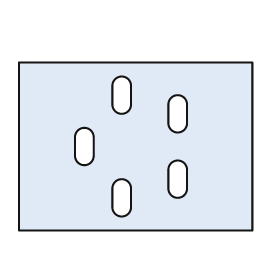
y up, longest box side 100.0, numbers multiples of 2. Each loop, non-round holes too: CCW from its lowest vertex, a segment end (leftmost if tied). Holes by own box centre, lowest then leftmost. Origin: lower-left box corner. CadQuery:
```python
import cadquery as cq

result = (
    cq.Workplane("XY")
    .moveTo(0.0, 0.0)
    .lineTo(100.0, 0.0)
    .lineTo(100.0, 72.0)
    .lineTo(0.0, 72.0)
    .close()
    .moveTo(40.0, 10.0)
    .threePointArc((44.0, 6.0), (48.0, 10.0))
    .lineTo(48.0, 18.0)
    .threePointArc((44.0, 22.0), (40.0, 18.0))
    .close()
    .moveTo(64.0, 18.0)
    .threePointArc((68.0, 14.0), (72.0, 18.0))
    .lineTo(72.0, 26.0)
    .threePointArc((68.0, 30.0), (64.0, 26.0))
    .close()
    .moveTo(24.0, 32.0)
    .threePointArc((28.0, 28.0), (32.0, 32.0))
    .lineTo(32.0, 40.0)
    .threePointArc((28.0, 44.0), (24.0, 40.0))
    .close()
    .moveTo(64.0, 46.0)
    .threePointArc((68.0, 42.0), (72.0, 46.0))
    .lineTo(72.0, 54.0)
    .threePointArc((68.0, 58.0), (64.0, 54.0))
    .close()
    .moveTo(40.0, 54.0)
    .threePointArc((44.0, 50.0), (48.0, 54.0))
    .lineTo(48.0, 62.0)
    .threePointArc((44.0, 66.0), (40.0, 62.0))
    .close()
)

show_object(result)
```